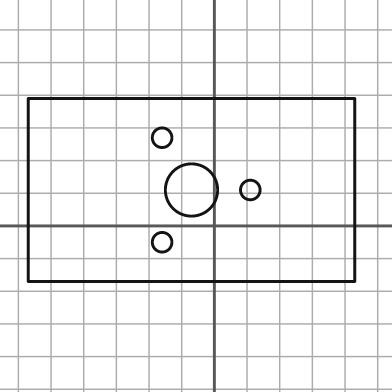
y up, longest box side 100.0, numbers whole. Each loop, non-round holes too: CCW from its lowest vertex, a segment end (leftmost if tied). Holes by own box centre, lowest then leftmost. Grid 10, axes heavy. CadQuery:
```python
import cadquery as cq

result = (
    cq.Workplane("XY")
    .moveTo(-57.0, -17.0)
    .lineTo(43.0, -17.0)
    .lineTo(43.0, 39.0)
    .lineTo(-57.0, 39.0)
    .close()
    .moveTo(-16.0, -5.0)
    .circle(3.0)
    .moveTo(-7.0, 11.0)
    .circle(8.0)
    .moveTo(11.0, 11.0)
    .circle(3.0)
    .moveTo(-16.0, 27.0)
    .circle(3.0)
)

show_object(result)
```